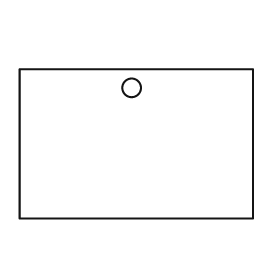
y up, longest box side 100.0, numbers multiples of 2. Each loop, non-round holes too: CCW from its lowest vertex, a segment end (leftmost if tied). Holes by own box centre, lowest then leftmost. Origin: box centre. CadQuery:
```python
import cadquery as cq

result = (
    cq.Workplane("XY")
    .moveTo(-50.0, -32.0)
    .lineTo(50.0, -32.0)
    .lineTo(50.0, 32.0)
    .lineTo(-50.0, 32.0)
    .close()
    .moveTo(-2.0, 24.0)
    .circle(4.0)
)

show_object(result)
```